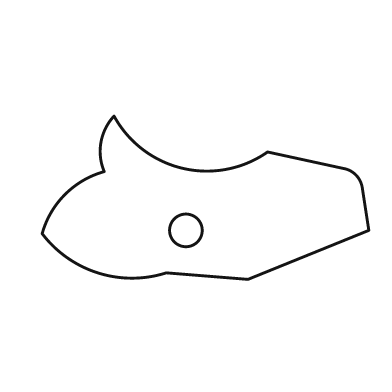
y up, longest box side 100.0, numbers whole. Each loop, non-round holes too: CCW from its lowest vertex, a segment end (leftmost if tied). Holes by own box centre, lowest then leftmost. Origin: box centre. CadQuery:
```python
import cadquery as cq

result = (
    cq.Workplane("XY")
    .moveTo(13.0, -25.0)
    .lineTo(50.0, -10.0)
    .lineTo(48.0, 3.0)
    .threePointArc((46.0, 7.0), (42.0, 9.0))
    .lineTo(19.0, 14.0)
    .threePointArc((-7.0, 9.0), (-28.0, 25.0))
    .threePointArc((-32.0, 17.0), (-31.0, 8.0))
    .threePointArc((-43.0, 1.0), (-50.0, -11.0))
    .threePointArc((-33.0, -23.0), (-12.0, -23.0))
    .close()
    .moveTo(-6.0, -10.0)
    .circle(5.0)
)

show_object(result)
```